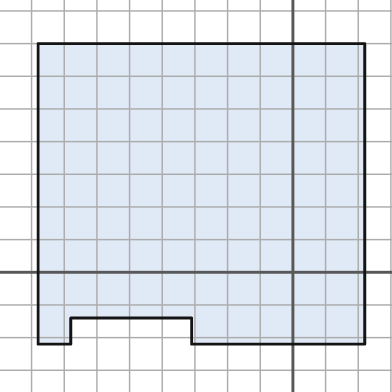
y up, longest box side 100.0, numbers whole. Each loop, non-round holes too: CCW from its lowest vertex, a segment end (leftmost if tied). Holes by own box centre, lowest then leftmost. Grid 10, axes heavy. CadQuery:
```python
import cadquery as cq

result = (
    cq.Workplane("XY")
    .moveTo(-78.0, -22.0)
    .lineTo(-68.0, -22.0)
    .lineTo(-68.0, -14.0)
    .lineTo(-31.0, -14.0)
    .lineTo(-31.0, -22.0)
    .lineTo(22.0, -22.0)
    .lineTo(22.0, 70.0)
    .lineTo(-78.0, 70.0)
    .close()
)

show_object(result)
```